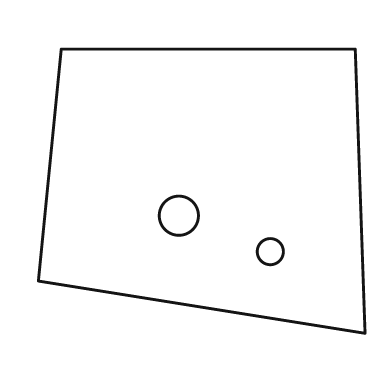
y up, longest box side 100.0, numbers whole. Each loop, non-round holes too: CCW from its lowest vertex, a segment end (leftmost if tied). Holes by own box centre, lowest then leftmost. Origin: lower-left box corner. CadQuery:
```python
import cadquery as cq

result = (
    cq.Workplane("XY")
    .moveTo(100.0, 0.0)
    .lineTo(97.0, 87.0)
    .lineTo(7.0, 87.0)
    .lineTo(0.0, 16.0)
    .close()
    .moveTo(71.0, 25.0)
    .circle(4.0)
    .moveTo(43.0, 36.0)
    .circle(6.0)
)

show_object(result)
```